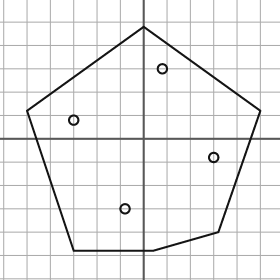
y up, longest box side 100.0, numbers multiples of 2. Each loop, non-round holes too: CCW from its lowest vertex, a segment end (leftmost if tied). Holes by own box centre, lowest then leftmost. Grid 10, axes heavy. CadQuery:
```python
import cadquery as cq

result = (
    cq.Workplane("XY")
    .moveTo(-30.0, -48.0)
    .lineTo(4.0, -48.0)
    .lineTo(32.0, -40.0)
    .lineTo(50.0, 12.0)
    .lineTo(0.0, 48.0)
    .lineTo(-50.0, 12.0)
    .close()
    .moveTo(-8.0, -30.0)
    .circle(2.0)
    .moveTo(30.0, -8.0)
    .circle(2.0)
    .moveTo(-30.0, 8.0)
    .circle(2.0)
    .moveTo(8.0, 30.0)
    .circle(2.0)
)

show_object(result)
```